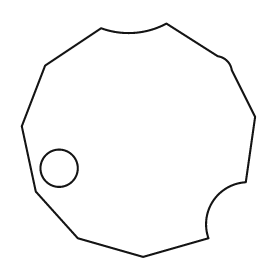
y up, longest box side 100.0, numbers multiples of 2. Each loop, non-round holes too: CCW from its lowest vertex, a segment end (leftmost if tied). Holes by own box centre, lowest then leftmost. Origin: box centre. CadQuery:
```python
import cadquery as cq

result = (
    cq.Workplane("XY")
    .moveTo(2.0, -50.0)
    .lineTo(30.0, -42.0)
    .threePointArc((32.0, -26.0), (46.0, -18.0))
    .lineTo(50.0, 10.0)
    .lineTo(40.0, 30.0)
    .threePointArc((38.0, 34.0), (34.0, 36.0))
    .lineTo(12.0, 50.0)
    .threePointArc((-2.0, 46.0), (-16.0, 48.0))
    .lineTo(-40.0, 32.0)
    .lineTo(-50.0, 6.0)
    .lineTo(-44.0, -22.0)
    .lineTo(-26.0, -42.0)
    .close()
    .moveTo(-34.0, -12.0)
    .circle(8.0)
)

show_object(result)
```